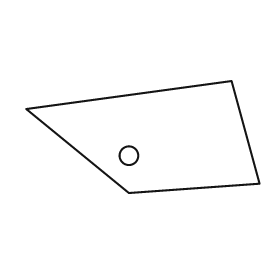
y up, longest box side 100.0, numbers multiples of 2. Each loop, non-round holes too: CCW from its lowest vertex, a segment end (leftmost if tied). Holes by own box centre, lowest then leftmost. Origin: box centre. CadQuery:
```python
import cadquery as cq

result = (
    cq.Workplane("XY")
    .moveTo(-6.0, -24.0)
    .lineTo(50.0, -20.0)
    .lineTo(38.0, 24.0)
    .lineTo(-50.0, 12.0)
    .close()
    .moveTo(-6.0, -8.0)
    .circle(4.0)
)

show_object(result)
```